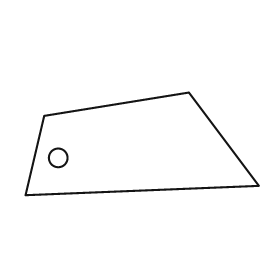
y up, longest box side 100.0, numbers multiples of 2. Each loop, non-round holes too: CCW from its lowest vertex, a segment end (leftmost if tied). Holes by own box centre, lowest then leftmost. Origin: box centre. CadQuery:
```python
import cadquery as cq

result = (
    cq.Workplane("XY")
    .moveTo(-50.0, -22.0)
    .lineTo(50.0, -18.0)
    .lineTo(20.0, 22.0)
    .lineTo(-42.0, 12.0)
    .close()
    .moveTo(-36.0, -6.0)
    .circle(4.0)
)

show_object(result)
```